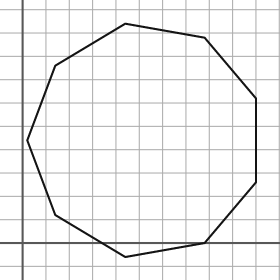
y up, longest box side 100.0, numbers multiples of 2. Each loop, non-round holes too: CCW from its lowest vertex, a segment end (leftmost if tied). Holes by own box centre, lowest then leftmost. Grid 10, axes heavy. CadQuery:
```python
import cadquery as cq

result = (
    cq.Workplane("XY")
    .moveTo(44.0, -6.0)
    .lineTo(78.0, 0.0)
    .lineTo(100.0, 26.0)
    .lineTo(100.0, 62.0)
    .lineTo(78.0, 88.0)
    .lineTo(44.0, 94.0)
    .lineTo(14.0, 76.0)
    .lineTo(2.0, 44.0)
    .lineTo(14.0, 12.0)
    .close()
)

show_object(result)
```